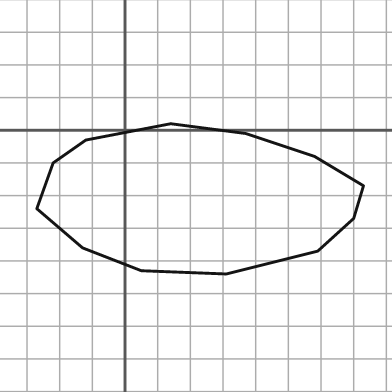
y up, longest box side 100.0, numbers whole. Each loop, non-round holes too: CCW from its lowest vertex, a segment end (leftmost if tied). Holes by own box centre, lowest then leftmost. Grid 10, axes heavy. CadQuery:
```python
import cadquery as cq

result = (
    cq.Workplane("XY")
    .moveTo(31.0, -44.0)
    .lineTo(59.0, -37.0)
    .lineTo(70.0, -27.0)
    .lineTo(73.0, -17.0)
    .lineTo(58.0, -8.0)
    .lineTo(37.0, -1.0)
    .lineTo(14.0, 2.0)
    .lineTo(-12.0, -3.0)
    .lineTo(-22.0, -10.0)
    .lineTo(-27.0, -24.0)
    .lineTo(-13.0, -36.0)
    .lineTo(5.0, -43.0)
    .close()
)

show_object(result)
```